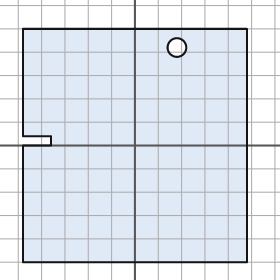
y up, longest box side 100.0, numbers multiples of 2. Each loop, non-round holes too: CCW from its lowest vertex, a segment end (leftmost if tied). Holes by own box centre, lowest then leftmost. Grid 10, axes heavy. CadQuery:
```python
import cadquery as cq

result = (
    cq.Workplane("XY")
    .moveTo(-48.0, -50.0)
    .lineTo(48.0, -50.0)
    .lineTo(48.0, 50.0)
    .lineTo(-48.0, 50.0)
    .lineTo(-48.0, 4.0)
    .lineTo(-36.0, 4.0)
    .lineTo(-36.0, 0.0)
    .lineTo(-48.0, 0.0)
    .close()
    .moveTo(18.0, 42.0)
    .circle(4.0)
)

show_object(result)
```